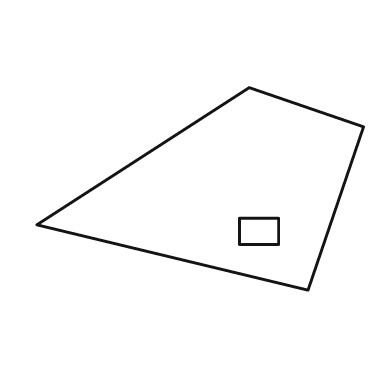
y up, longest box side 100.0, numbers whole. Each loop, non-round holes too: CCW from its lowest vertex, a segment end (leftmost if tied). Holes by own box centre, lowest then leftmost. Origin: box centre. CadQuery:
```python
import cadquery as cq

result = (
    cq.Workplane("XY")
    .moveTo(33.0, -31.0)
    .lineTo(50.0, 19.0)
    .lineTo(15.0, 31.0)
    .lineTo(-50.0, -11.0)
    .close()
    .moveTo(12.0, -17.0)
    .lineTo(24.0, -17.0)
    .lineTo(24.0, -9.0)
    .lineTo(12.0, -9.0)
    .close()
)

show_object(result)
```